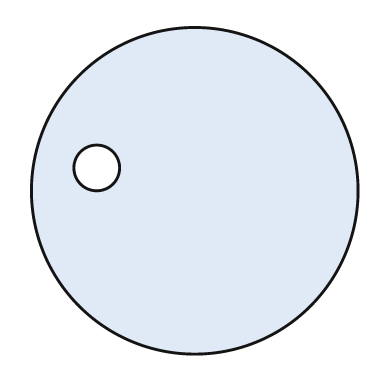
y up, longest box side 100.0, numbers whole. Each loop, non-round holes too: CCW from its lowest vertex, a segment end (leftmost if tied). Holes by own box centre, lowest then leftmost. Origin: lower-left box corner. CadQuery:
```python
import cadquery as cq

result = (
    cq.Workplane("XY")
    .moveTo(50.0, 50.0)
    .circle(50.0)
    .moveTo(20.0, 57.0)
    .circle(7.0)
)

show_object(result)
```